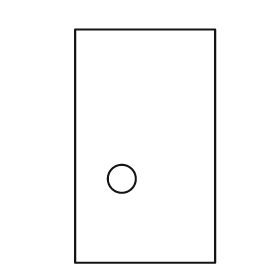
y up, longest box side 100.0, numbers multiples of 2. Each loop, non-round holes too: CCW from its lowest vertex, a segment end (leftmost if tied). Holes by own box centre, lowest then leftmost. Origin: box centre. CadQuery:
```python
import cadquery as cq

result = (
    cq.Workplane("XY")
    .moveTo(-30.0, -50.0)
    .lineTo(30.0, -50.0)
    .lineTo(30.0, 50.0)
    .lineTo(-30.0, 50.0)
    .close()
    .moveTo(-10.0, -14.0)
    .circle(6.0)
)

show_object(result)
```